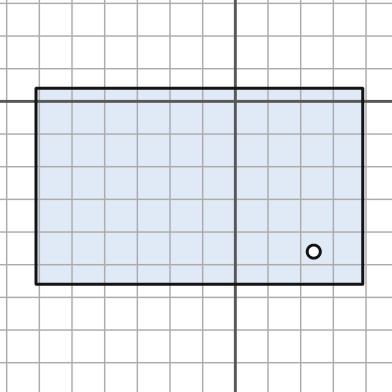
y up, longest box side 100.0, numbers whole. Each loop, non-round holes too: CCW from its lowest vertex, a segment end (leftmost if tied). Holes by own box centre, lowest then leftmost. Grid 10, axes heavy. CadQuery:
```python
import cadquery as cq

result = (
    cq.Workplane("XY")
    .moveTo(-61.0, -56.0)
    .lineTo(39.0, -56.0)
    .lineTo(39.0, 4.0)
    .lineTo(-61.0, 4.0)
    .close()
    .moveTo(24.0, -46.0)
    .circle(2.0)
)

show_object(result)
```